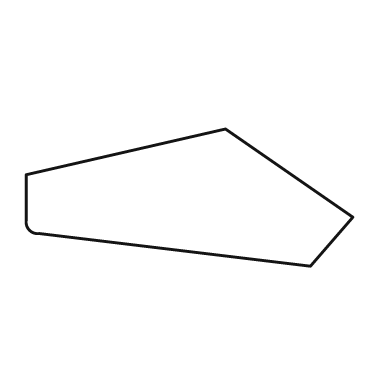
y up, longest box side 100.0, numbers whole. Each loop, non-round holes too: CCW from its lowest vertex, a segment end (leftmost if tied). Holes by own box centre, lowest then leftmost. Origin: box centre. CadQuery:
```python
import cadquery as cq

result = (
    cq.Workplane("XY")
    .moveTo(37.0, -21.0)
    .lineTo(50.0, -6.0)
    .lineTo(11.0, 21.0)
    .lineTo(-50.0, 7.0)
    .lineTo(-50.0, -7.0)
    .threePointArc((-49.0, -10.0), (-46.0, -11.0))
    .close()
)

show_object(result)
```